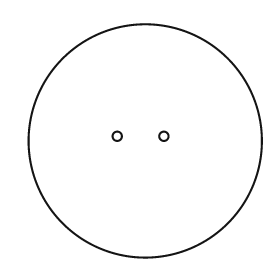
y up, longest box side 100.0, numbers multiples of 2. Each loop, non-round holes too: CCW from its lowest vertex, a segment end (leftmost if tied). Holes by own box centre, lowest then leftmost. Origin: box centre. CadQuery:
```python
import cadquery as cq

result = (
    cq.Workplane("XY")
    .moveTo(0.0, 0.0)
    .circle(50.0)
    .moveTo(-12.0, 2.0)
    .circle(2.0)
    .moveTo(8.0, 2.0)
    .circle(2.0)
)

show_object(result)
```